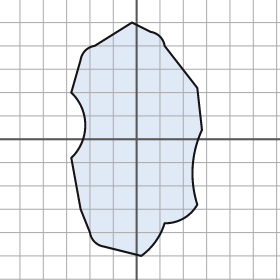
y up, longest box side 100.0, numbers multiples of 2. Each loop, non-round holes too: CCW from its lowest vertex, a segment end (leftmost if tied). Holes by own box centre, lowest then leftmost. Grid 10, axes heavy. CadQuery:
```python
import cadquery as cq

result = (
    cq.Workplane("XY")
    .moveTo(2.0, -50.0)
    .threePointArc((8.0, -44.0), (12.0, -36.0))
    .threePointArc((20.0, -34.0), (26.0, -28.0))
    .threePointArc((24.0, -12.0), (28.0, 4.0))
    .lineTo(26.0, 22.0)
    .lineTo(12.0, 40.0)
    .threePointArc((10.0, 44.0), (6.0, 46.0))
    .lineTo(-2.0, 50.0)
    .lineTo(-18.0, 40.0)
    .threePointArc((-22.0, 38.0), (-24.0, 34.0))
    .lineTo(-28.0, 20.0)
    .threePointArc((-22.0, 6.0), (-28.0, -8.0))
    .lineTo(-24.0, -30.0)
    .lineTo(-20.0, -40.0)
    .threePointArc((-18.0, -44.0), (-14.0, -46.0))
    .close()
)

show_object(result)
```